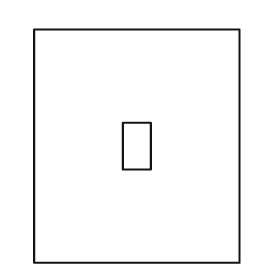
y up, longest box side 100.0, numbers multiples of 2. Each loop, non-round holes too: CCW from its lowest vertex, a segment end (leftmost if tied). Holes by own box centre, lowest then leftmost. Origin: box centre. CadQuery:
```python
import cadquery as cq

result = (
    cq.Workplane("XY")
    .moveTo(-44.0, -50.0)
    .lineTo(44.0, -50.0)
    .lineTo(44.0, 50.0)
    .lineTo(-44.0, 50.0)
    .close()
    .moveTo(-6.0, -10.0)
    .lineTo(6.0, -10.0)
    .lineTo(6.0, 10.0)
    .lineTo(-6.0, 10.0)
    .close()
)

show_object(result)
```